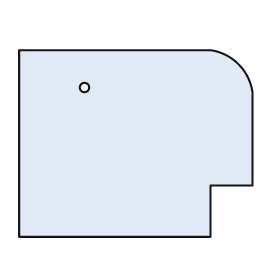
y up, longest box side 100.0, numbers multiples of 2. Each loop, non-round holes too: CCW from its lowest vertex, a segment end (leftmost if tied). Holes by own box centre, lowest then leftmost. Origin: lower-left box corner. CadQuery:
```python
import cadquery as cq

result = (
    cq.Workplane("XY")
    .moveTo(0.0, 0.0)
    .lineTo(82.0, 0.0)
    .lineTo(82.0, 22.0)
    .lineTo(100.0, 22.0)
    .lineTo(100.0, 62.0)
    .threePointArc((94.0, 74.0), (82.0, 80.0))
    .lineTo(0.0, 80.0)
    .close()
    .moveTo(28.0, 64.0)
    .circle(2.0)
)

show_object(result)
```